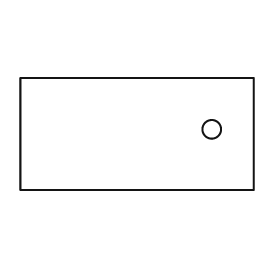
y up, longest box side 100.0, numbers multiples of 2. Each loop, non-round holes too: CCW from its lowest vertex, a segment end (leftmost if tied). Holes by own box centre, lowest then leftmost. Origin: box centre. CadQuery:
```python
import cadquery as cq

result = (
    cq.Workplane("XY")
    .moveTo(-50.0, -24.0)
    .lineTo(50.0, -24.0)
    .lineTo(50.0, 24.0)
    .lineTo(-50.0, 24.0)
    .close()
    .moveTo(32.0, 2.0)
    .circle(4.0)
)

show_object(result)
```